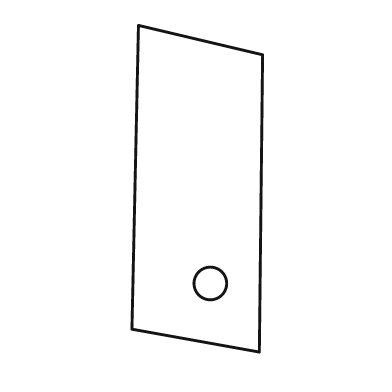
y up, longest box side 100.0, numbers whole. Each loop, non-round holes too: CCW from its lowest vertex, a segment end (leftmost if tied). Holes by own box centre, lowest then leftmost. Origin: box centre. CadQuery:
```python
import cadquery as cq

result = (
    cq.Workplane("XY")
    .moveTo(19.0, -50.0)
    .lineTo(20.0, 41.0)
    .lineTo(-18.0, 50.0)
    .lineTo(-20.0, -43.0)
    .close()
    .moveTo(4.0, -29.0)
    .circle(5.0)
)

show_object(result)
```